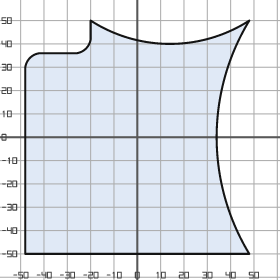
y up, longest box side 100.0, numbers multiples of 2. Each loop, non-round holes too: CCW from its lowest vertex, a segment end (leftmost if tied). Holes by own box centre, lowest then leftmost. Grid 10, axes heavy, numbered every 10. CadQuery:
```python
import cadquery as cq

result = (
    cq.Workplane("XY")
    .moveTo(-48.0, -50.0)
    .lineTo(48.0, -50.0)
    .threePointArc((34.0, 0.0), (48.0, 50.0))
    .threePointArc((14.0, 40.0), (-20.0, 50.0))
    .lineTo(-20.0, 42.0)
    .threePointArc((-22.0, 38.0), (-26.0, 36.0))
    .lineTo(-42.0, 36.0)
    .threePointArc((-46.0, 34.0), (-48.0, 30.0))
    .close()
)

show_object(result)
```